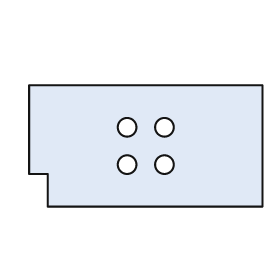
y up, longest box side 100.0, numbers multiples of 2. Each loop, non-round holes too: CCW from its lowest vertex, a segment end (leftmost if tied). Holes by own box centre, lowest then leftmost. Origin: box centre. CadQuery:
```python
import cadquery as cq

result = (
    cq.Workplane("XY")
    .moveTo(-42.0, -26.0)
    .lineTo(50.0, -26.0)
    .lineTo(50.0, 26.0)
    .lineTo(-50.0, 26.0)
    .lineTo(-50.0, -12.0)
    .lineTo(-42.0, -12.0)
    .close()
    .moveTo(-8.0, -8.0)
    .circle(4.0)
    .moveTo(8.0, -8.0)
    .circle(4.0)
    .moveTo(-8.0, 8.0)
    .circle(4.0)
    .moveTo(8.0, 8.0)
    .circle(4.0)
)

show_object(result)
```